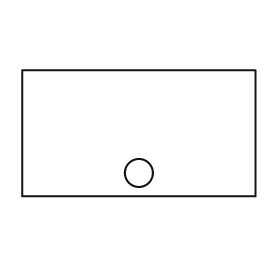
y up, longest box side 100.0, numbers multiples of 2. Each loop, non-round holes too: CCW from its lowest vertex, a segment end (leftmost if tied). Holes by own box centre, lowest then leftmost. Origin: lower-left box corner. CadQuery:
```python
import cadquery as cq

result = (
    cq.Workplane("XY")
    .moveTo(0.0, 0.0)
    .lineTo(100.0, 0.0)
    .lineTo(100.0, 54.0)
    .lineTo(0.0, 54.0)
    .close()
    .moveTo(50.0, 10.0)
    .circle(6.0)
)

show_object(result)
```